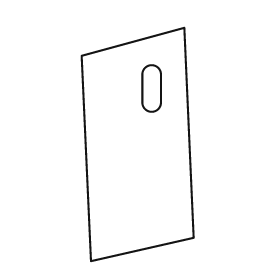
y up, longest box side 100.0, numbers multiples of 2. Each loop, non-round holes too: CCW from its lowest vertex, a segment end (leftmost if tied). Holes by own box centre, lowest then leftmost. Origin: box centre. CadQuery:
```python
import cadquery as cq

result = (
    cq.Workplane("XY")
    .moveTo(-20.0, -50.0)
    .lineTo(24.0, -40.0)
    .lineTo(20.0, 50.0)
    .lineTo(-24.0, 38.0)
    .close()
    .moveTo(2.0, 18.0)
    .threePointArc((6.0, 14.0), (10.0, 18.0))
    .lineTo(10.0, 30.0)
    .threePointArc((6.0, 34.0), (2.0, 30.0))
    .close()
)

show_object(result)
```